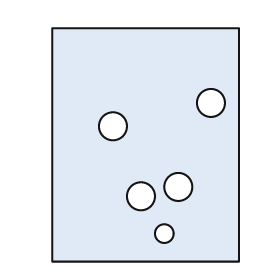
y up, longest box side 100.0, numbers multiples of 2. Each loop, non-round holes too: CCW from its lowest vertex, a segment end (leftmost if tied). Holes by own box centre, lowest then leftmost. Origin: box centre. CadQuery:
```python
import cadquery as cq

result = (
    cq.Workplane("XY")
    .moveTo(-40.0, -50.0)
    .lineTo(40.0, -50.0)
    .lineTo(40.0, 50.0)
    .lineTo(-40.0, 50.0)
    .close()
    .moveTo(8.0, -38.0)
    .circle(4.0)
    .moveTo(-2.0, -22.0)
    .circle(6.0)
    .moveTo(14.0, -18.0)
    .circle(6.0)
    .moveTo(-14.0, 8.0)
    .circle(6.0)
    .moveTo(28.0, 18.0)
    .circle(6.0)
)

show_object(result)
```